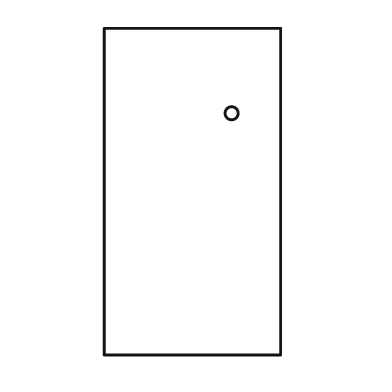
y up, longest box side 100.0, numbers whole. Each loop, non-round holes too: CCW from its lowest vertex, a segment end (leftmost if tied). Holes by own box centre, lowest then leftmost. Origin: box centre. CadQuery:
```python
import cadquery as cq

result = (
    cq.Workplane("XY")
    .moveTo(-27.0, -50.0)
    .lineTo(27.0, -50.0)
    .lineTo(27.0, 50.0)
    .lineTo(-27.0, 50.0)
    .close()
    .moveTo(12.0, 24.0)
    .circle(2.0)
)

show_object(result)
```